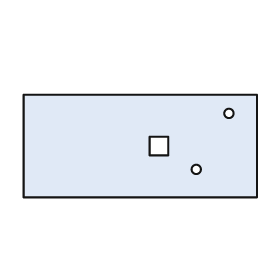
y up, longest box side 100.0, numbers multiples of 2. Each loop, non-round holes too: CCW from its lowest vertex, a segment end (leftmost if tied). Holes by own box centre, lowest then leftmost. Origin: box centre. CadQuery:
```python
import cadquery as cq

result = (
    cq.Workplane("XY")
    .moveTo(-50.0, -22.0)
    .lineTo(50.0, -22.0)
    .lineTo(50.0, 22.0)
    .lineTo(-50.0, 22.0)
    .close()
    .moveTo(24.0, -10.0)
    .circle(2.0)
    .moveTo(4.0, -4.0)
    .lineTo(12.0, -4.0)
    .lineTo(12.0, 4.0)
    .lineTo(4.0, 4.0)
    .close()
    .moveTo(38.0, 14.0)
    .circle(2.0)
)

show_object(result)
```